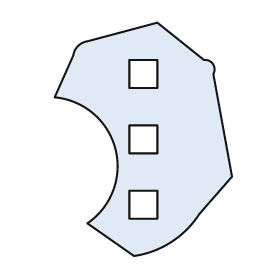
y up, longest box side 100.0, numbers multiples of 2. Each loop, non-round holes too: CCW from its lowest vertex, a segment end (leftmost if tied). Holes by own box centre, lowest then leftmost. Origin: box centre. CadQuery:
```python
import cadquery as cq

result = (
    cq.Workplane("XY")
    .moveTo(-4.0, -50.0)
    .threePointArc((12.0, -44.0), (24.0, -32.0))
    .lineTo(38.0, -16.0)
    .lineTo(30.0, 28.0)
    .threePointArc((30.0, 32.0), (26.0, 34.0))
    .lineTo(6.0, 50.0)
    .lineTo(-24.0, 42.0)
    .threePointArc((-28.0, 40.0), (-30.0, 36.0))
    .lineTo(-38.0, 18.0)
    .threePointArc((-12.0, -4.0), (-24.0, -36.0))
    .close()
    .moveTo(-6.0, -34.0)
    .lineTo(6.0, -34.0)
    .lineTo(6.0, -22.0)
    .lineTo(-6.0, -22.0)
    .close()
    .moveTo(-6.0, -6.0)
    .lineTo(6.0, -6.0)
    .lineTo(6.0, 6.0)
    .lineTo(-6.0, 6.0)
    .close()
    .moveTo(-6.0, 22.0)
    .lineTo(6.0, 22.0)
    .lineTo(6.0, 34.0)
    .lineTo(-6.0, 34.0)
    .close()
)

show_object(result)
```